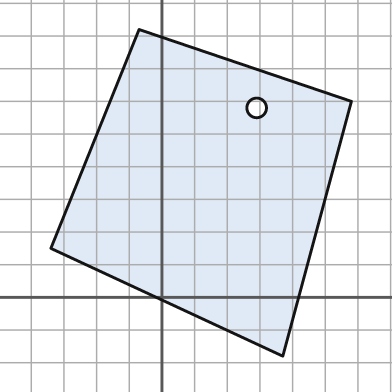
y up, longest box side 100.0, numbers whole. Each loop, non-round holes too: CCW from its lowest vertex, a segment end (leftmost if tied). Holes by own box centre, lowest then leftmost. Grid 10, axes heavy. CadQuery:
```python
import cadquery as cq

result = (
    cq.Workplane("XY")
    .moveTo(37.0, -18.0)
    .lineTo(58.0, 60.0)
    .lineTo(-7.0, 82.0)
    .lineTo(-34.0, 15.0)
    .close()
    .moveTo(29.0, 58.0)
    .circle(3.0)
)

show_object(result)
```